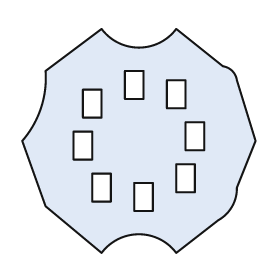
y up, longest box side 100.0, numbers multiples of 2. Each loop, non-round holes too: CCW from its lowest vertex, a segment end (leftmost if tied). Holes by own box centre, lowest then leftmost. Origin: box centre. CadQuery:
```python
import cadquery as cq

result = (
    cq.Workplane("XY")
    .moveTo(-16.0, -48.0)
    .threePointArc((0.0, -40.0), (16.0, -48.0))
    .lineTo(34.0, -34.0)
    .threePointArc((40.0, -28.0), (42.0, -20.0))
    .lineTo(50.0, 0.0)
    .lineTo(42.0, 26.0)
    .threePointArc((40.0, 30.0), (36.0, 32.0))
    .lineTo(16.0, 48.0)
    .threePointArc((0.0, 40.0), (-16.0, 48.0))
    .lineTo(-40.0, 30.0)
    .threePointArc((-42.0, 14.0), (-50.0, 0.0))
    .lineTo(-40.0, -28.0)
    .close()
    .moveTo(-2.0, -30.0)
    .lineTo(6.0, -30.0)
    .lineTo(6.0, -18.0)
    .lineTo(-2.0, -18.0)
    .close()
    .moveTo(-20.0, -26.0)
    .lineTo(-12.0, -26.0)
    .lineTo(-12.0, -14.0)
    .lineTo(-20.0, -14.0)
    .close()
    .moveTo(16.0, -22.0)
    .lineTo(24.0, -22.0)
    .lineTo(24.0, -10.0)
    .lineTo(16.0, -10.0)
    .close()
    .moveTo(-28.0, -8.0)
    .lineTo(-20.0, -8.0)
    .lineTo(-20.0, 4.0)
    .lineTo(-28.0, 4.0)
    .close()
    .moveTo(20.0, -4.0)
    .lineTo(28.0, -4.0)
    .lineTo(28.0, 8.0)
    .lineTo(20.0, 8.0)
    .close()
    .moveTo(-24.0, 10.0)
    .lineTo(-16.0, 10.0)
    .lineTo(-16.0, 22.0)
    .lineTo(-24.0, 22.0)
    .close()
    .moveTo(12.0, 14.0)
    .lineTo(20.0, 14.0)
    .lineTo(20.0, 26.0)
    .lineTo(12.0, 26.0)
    .close()
    .moveTo(-6.0, 18.0)
    .lineTo(2.0, 18.0)
    .lineTo(2.0, 30.0)
    .lineTo(-6.0, 30.0)
    .close()
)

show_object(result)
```